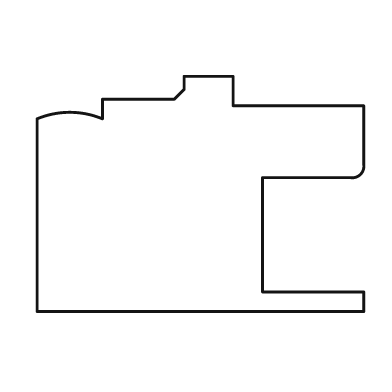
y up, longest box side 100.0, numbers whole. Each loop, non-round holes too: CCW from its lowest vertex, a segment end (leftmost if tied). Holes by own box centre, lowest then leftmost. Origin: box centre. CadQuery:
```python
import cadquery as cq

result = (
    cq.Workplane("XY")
    .moveTo(-50.0, -36.0)
    .lineTo(50.0, -36.0)
    .lineTo(50.0, -30.0)
    .lineTo(19.0, -30.0)
    .lineTo(19.0, 5.0)
    .lineTo(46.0, 5.0)
    .threePointArc((49.0, 6.0), (50.0, 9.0))
    .lineTo(50.0, 27.0)
    .lineTo(10.0, 27.0)
    .lineTo(10.0, 36.0)
    .lineTo(-5.0, 36.0)
    .lineTo(-5.0, 32.0)
    .lineTo(-8.0, 29.0)
    .lineTo(-30.0, 29.0)
    .lineTo(-30.0, 23.0)
    .threePointArc((-40.0, 25.0), (-50.0, 23.0))
    .close()
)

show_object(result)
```